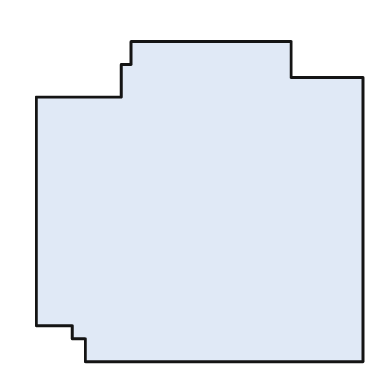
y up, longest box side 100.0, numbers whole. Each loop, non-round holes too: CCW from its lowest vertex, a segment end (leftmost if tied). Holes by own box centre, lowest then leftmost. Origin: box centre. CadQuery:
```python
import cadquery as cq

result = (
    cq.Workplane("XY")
    .moveTo(-35.0, -49.0)
    .lineTo(50.0, -49.0)
    .lineTo(50.0, 38.0)
    .lineTo(28.0, 38.0)
    .lineTo(28.0, 49.0)
    .lineTo(-21.0, 49.0)
    .lineTo(-21.0, 42.0)
    .lineTo(-24.0, 42.0)
    .lineTo(-24.0, 32.0)
    .lineTo(-50.0, 32.0)
    .lineTo(-50.0, -38.0)
    .lineTo(-39.0, -38.0)
    .lineTo(-39.0, -42.0)
    .lineTo(-35.0, -42.0)
    .close()
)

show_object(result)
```